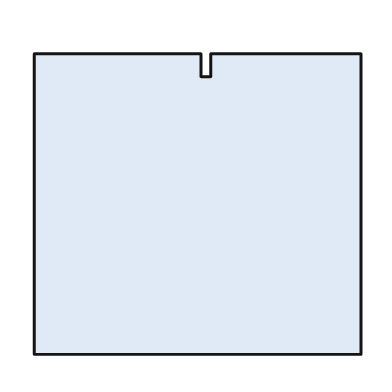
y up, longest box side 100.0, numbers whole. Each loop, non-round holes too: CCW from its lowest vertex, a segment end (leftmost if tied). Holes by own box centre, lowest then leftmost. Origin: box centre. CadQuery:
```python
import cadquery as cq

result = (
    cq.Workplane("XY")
    .moveTo(-50.0, -46.0)
    .lineTo(50.0, -46.0)
    .lineTo(50.0, 46.0)
    .lineTo(4.0, 46.0)
    .lineTo(4.0, 39.0)
    .lineTo(1.0, 39.0)
    .lineTo(1.0, 46.0)
    .lineTo(-50.0, 46.0)
    .close()
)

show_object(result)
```